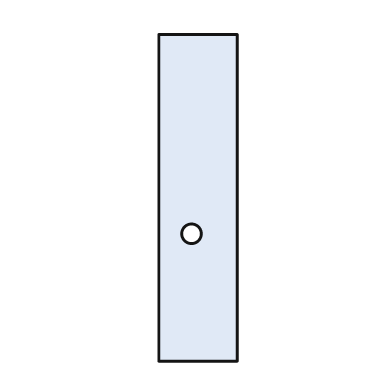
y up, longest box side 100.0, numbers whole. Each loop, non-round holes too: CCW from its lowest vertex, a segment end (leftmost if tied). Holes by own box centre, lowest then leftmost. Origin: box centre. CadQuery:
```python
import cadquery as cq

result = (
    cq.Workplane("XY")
    .moveTo(-12.0, -50.0)
    .lineTo(12.0, -50.0)
    .lineTo(12.0, 50.0)
    .lineTo(-12.0, 50.0)
    .close()
    .moveTo(-2.0, -11.0)
    .circle(3.0)
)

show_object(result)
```